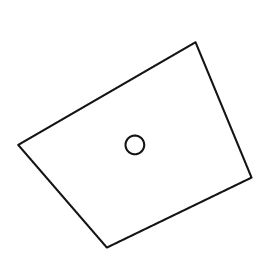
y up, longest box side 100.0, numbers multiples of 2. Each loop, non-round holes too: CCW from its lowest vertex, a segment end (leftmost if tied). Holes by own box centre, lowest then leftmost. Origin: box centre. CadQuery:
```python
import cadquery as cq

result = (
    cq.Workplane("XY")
    .moveTo(-12.0, -44.0)
    .lineTo(50.0, -14.0)
    .lineTo(26.0, 44.0)
    .lineTo(-50.0, 0.0)
    .close()
    .moveTo(0.0, 0.0)
    .circle(4.0)
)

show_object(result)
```